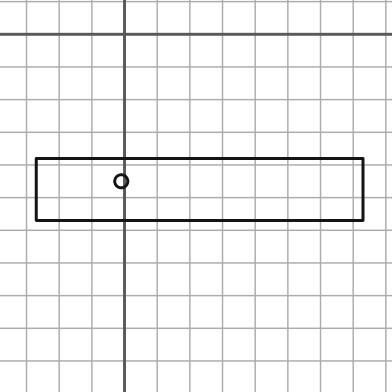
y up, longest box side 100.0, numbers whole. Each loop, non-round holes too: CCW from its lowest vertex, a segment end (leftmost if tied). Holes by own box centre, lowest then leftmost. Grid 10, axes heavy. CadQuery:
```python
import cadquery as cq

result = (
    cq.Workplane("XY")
    .moveTo(-27.0, -57.0)
    .lineTo(73.0, -57.0)
    .lineTo(73.0, -38.0)
    .lineTo(-27.0, -38.0)
    .close()
    .moveTo(-1.0, -45.0)
    .circle(2.0)
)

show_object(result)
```